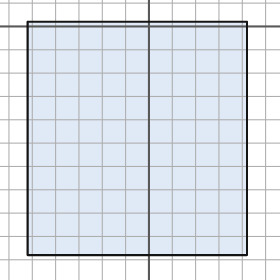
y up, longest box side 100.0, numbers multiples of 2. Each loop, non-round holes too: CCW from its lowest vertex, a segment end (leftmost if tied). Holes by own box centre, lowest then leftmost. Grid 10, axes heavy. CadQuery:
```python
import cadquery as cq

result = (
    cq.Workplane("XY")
    .moveTo(-52.0, -98.0)
    .lineTo(42.0, -98.0)
    .lineTo(42.0, 2.0)
    .lineTo(-52.0, 2.0)
    .close()
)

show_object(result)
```